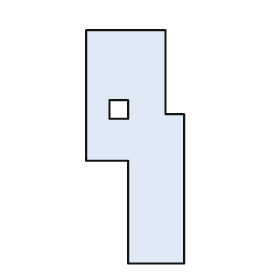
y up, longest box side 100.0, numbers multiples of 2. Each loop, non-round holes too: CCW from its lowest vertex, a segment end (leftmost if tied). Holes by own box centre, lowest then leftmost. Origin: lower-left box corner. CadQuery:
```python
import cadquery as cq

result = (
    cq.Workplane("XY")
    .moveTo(18.0, 0.0)
    .lineTo(42.0, 0.0)
    .lineTo(42.0, 64.0)
    .lineTo(34.0, 64.0)
    .lineTo(34.0, 100.0)
    .lineTo(0.0, 100.0)
    .lineTo(0.0, 44.0)
    .lineTo(18.0, 44.0)
    .close()
    .moveTo(10.0, 62.0)
    .lineTo(18.0, 62.0)
    .lineTo(18.0, 70.0)
    .lineTo(10.0, 70.0)
    .close()
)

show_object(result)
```